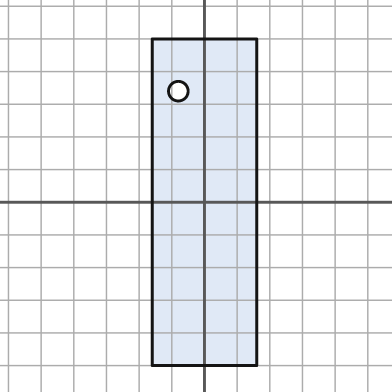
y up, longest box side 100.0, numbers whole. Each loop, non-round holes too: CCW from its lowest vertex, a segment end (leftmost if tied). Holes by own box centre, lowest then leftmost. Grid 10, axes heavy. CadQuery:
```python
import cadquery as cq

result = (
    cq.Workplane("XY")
    .moveTo(-16.0, -50.0)
    .lineTo(16.0, -50.0)
    .lineTo(16.0, 50.0)
    .lineTo(-16.0, 50.0)
    .close()
    .moveTo(-8.0, 34.0)
    .circle(3.0)
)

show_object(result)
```